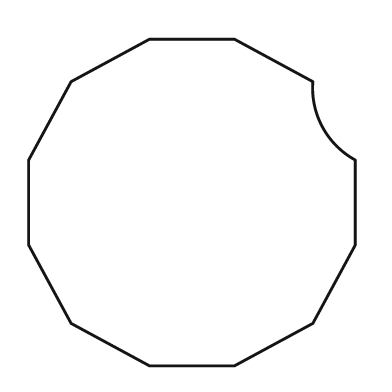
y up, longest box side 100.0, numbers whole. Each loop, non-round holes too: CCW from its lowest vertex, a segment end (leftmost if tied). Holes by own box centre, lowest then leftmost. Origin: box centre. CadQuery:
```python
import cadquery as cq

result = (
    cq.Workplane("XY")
    .moveTo(-13.0, -50.0)
    .lineTo(13.0, -50.0)
    .lineTo(37.0, -37.0)
    .lineTo(50.0, -13.0)
    .lineTo(50.0, 13.0)
    .threePointArc((40.0, 23.0), (37.0, 37.0))
    .lineTo(13.0, 50.0)
    .lineTo(-13.0, 50.0)
    .lineTo(-37.0, 37.0)
    .lineTo(-50.0, 13.0)
    .lineTo(-50.0, -13.0)
    .lineTo(-37.0, -37.0)
    .close()
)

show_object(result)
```